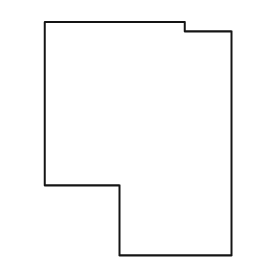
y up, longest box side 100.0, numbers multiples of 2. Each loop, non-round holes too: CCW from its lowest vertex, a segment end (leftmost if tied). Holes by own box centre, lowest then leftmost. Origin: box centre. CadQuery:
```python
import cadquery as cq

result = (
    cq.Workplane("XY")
    .moveTo(-8.0, -50.0)
    .lineTo(40.0, -50.0)
    .lineTo(40.0, 46.0)
    .lineTo(20.0, 46.0)
    .lineTo(20.0, 50.0)
    .lineTo(-40.0, 50.0)
    .lineTo(-40.0, -20.0)
    .lineTo(-8.0, -20.0)
    .close()
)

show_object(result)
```